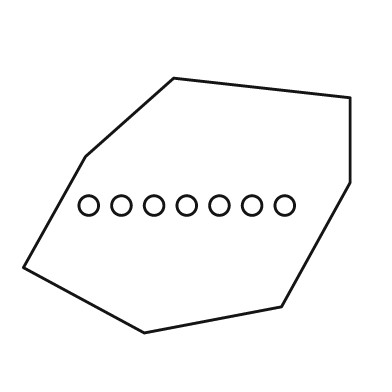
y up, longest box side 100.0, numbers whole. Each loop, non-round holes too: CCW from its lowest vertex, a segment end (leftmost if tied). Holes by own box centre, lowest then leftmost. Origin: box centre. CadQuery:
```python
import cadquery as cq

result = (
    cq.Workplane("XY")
    .moveTo(-13.0, -39.0)
    .lineTo(29.0, -31.0)
    .lineTo(50.0, 7.0)
    .lineTo(50.0, 33.0)
    .lineTo(-4.0, 39.0)
    .lineTo(-31.0, 15.0)
    .lineTo(-50.0, -19.0)
    .close()
    .moveTo(-30.0, 0.0)
    .circle(3.0)
    .moveTo(-20.0, 0.0)
    .circle(3.0)
    .moveTo(-10.0, 0.0)
    .circle(3.0)
    .moveTo(0.0, 0.0)
    .circle(3.0)
    .moveTo(10.0, 0.0)
    .circle(3.0)
    .moveTo(20.0, 0.0)
    .circle(3.0)
    .moveTo(30.0, 0.0)
    .circle(3.0)
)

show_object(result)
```